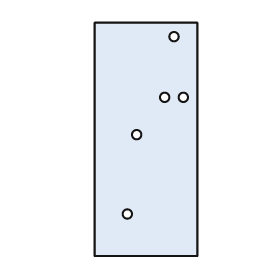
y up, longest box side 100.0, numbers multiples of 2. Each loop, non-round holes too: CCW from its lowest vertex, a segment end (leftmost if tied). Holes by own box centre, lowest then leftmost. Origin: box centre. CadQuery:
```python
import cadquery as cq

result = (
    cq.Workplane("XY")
    .moveTo(-22.0, -50.0)
    .lineTo(22.0, -50.0)
    .lineTo(22.0, 50.0)
    .lineTo(-22.0, 50.0)
    .close()
    .moveTo(-8.0, -32.0)
    .circle(2.0)
    .moveTo(-4.0, 2.0)
    .circle(2.0)
    .moveTo(8.0, 18.0)
    .circle(2.0)
    .moveTo(16.0, 18.0)
    .circle(2.0)
    .moveTo(12.0, 44.0)
    .circle(2.0)
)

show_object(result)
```